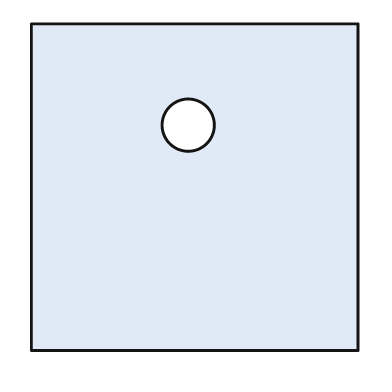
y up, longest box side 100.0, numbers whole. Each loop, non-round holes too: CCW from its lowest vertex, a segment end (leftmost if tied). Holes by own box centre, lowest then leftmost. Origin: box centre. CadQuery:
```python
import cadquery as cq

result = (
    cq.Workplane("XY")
    .moveTo(-50.0, -50.0)
    .lineTo(50.0, -50.0)
    .lineTo(50.0, 50.0)
    .lineTo(-50.0, 50.0)
    .close()
    .moveTo(-2.0, 19.0)
    .circle(8.0)
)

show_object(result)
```